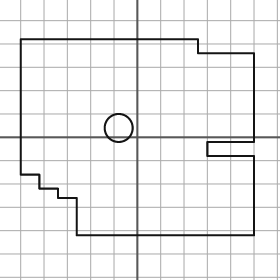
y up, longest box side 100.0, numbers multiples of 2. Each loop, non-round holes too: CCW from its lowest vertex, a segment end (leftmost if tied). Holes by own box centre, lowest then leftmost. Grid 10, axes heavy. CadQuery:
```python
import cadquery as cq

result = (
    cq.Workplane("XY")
    .moveTo(-26.0, -42.0)
    .lineTo(50.0, -42.0)
    .lineTo(50.0, -8.0)
    .lineTo(30.0, -8.0)
    .lineTo(30.0, -2.0)
    .lineTo(50.0, -2.0)
    .lineTo(50.0, 36.0)
    .lineTo(26.0, 36.0)
    .lineTo(26.0, 42.0)
    .lineTo(-50.0, 42.0)
    .lineTo(-50.0, -16.0)
    .lineTo(-42.0, -16.0)
    .lineTo(-42.0, -22.0)
    .lineTo(-34.0, -22.0)
    .lineTo(-34.0, -26.0)
    .lineTo(-26.0, -26.0)
    .close()
    .moveTo(-8.0, 4.0)
    .circle(6.0)
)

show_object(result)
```